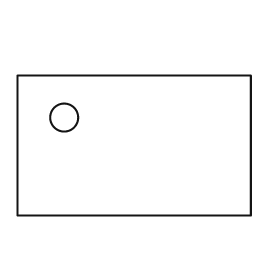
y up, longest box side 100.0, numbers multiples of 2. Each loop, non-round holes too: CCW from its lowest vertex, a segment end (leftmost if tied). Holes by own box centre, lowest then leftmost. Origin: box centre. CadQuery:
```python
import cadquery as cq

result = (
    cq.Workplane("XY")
    .moveTo(-50.0, -30.0)
    .lineTo(50.0, -30.0)
    .lineTo(50.0, 30.0)
    .lineTo(-50.0, 30.0)
    .close()
    .moveTo(-30.0, 12.0)
    .circle(6.0)
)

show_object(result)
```